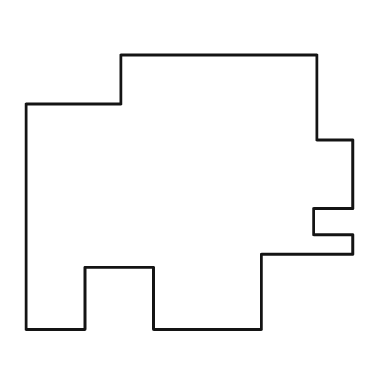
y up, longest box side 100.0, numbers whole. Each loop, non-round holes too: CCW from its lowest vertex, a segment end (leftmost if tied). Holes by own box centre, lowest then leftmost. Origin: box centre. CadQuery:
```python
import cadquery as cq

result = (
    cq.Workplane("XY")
    .moveTo(-50.0, -42.0)
    .lineTo(-32.0, -42.0)
    .lineTo(-32.0, -23.0)
    .lineTo(-11.0, -23.0)
    .lineTo(-11.0, -42.0)
    .lineTo(22.0, -42.0)
    .lineTo(22.0, -19.0)
    .lineTo(50.0, -19.0)
    .lineTo(50.0, -13.0)
    .lineTo(38.0, -13.0)
    .lineTo(38.0, -5.0)
    .lineTo(50.0, -5.0)
    .lineTo(50.0, 16.0)
    .lineTo(39.0, 16.0)
    .lineTo(39.0, 42.0)
    .lineTo(-21.0, 42.0)
    .lineTo(-21.0, 27.0)
    .lineTo(-50.0, 27.0)
    .close()
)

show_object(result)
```